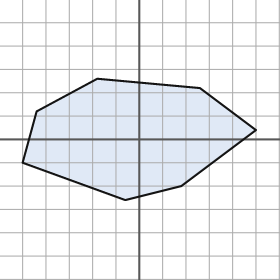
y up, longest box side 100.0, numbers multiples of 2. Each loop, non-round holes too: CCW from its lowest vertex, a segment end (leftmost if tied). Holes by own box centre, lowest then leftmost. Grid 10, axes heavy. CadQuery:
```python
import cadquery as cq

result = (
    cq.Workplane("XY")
    .moveTo(-6.0, -26.0)
    .lineTo(18.0, -20.0)
    .lineTo(50.0, 4.0)
    .lineTo(26.0, 22.0)
    .lineTo(-18.0, 26.0)
    .lineTo(-44.0, 12.0)
    .lineTo(-50.0, -10.0)
    .close()
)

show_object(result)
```